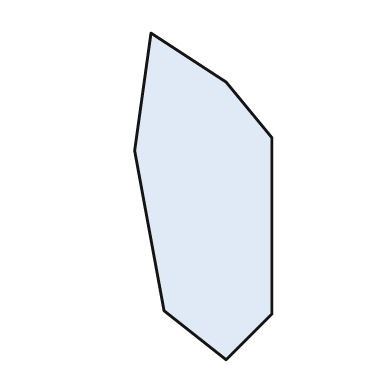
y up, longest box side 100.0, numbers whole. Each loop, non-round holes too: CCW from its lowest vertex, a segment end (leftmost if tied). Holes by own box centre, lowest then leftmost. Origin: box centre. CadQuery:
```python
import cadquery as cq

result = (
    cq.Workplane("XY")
    .moveTo(7.0, -50.0)
    .lineTo(21.0, -36.0)
    .lineTo(21.0, 18.0)
    .lineTo(7.0, 35.0)
    .lineTo(-16.0, 50.0)
    .lineTo(-21.0, 14.0)
    .lineTo(-12.0, -35.0)
    .close()
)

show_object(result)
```